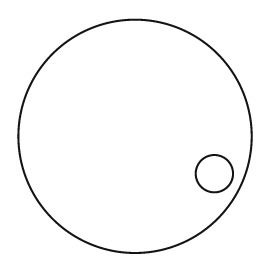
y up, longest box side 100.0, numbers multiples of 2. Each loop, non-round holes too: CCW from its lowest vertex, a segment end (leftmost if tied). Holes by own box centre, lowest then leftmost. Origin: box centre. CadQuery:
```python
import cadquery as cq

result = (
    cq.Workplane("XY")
    .moveTo(0.0, 0.0)
    .circle(50.0)
    .moveTo(34.0, -16.0)
    .circle(8.0)
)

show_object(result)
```